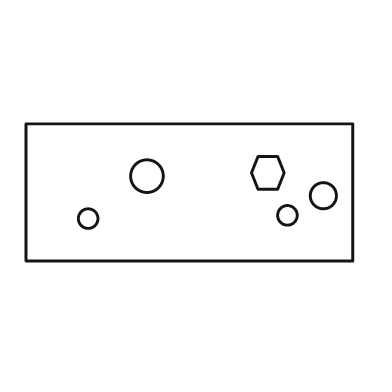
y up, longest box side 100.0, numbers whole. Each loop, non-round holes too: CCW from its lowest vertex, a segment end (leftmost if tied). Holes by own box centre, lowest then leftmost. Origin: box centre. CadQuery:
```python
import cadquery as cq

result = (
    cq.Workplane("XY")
    .moveTo(-50.0, -21.0)
    .lineTo(50.0, -21.0)
    .lineTo(50.0, 21.0)
    .lineTo(-50.0, 21.0)
    .close()
    .moveTo(-31.0, -8.0)
    .circle(3.0)
    .moveTo(30.0, -7.0)
    .circle(3.0)
    .moveTo(41.0, -1.0)
    .circle(4.0)
    .moveTo(-13.0, 5.0)
    .circle(5.0)
    .moveTo(21.0, 1.0)
    .lineTo(27.0, 1.0)
    .lineTo(29.0, 6.0)
    .lineTo(27.0, 11.0)
    .lineTo(21.0, 11.0)
    .lineTo(19.0, 6.0)
    .close()
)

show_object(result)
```